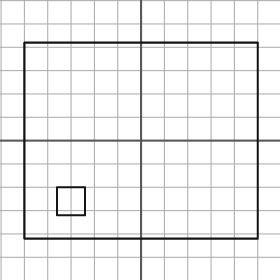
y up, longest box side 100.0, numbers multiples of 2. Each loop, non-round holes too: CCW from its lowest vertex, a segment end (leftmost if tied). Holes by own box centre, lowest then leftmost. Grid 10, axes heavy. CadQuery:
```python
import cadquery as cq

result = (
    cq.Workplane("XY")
    .moveTo(-50.0, -42.0)
    .lineTo(50.0, -42.0)
    .lineTo(50.0, 42.0)
    .lineTo(-50.0, 42.0)
    .close()
    .moveTo(-36.0, -32.0)
    .lineTo(-24.0, -32.0)
    .lineTo(-24.0, -20.0)
    .lineTo(-36.0, -20.0)
    .close()
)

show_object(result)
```